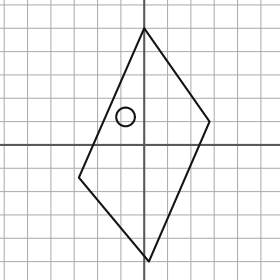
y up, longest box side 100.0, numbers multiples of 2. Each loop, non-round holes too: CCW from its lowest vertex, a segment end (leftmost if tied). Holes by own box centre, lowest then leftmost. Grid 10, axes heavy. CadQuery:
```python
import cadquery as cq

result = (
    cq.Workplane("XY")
    .moveTo(2.0, -50.0)
    .lineTo(28.0, 10.0)
    .lineTo(0.0, 50.0)
    .lineTo(-28.0, -14.0)
    .close()
    .moveTo(-8.0, 12.0)
    .circle(4.0)
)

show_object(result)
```